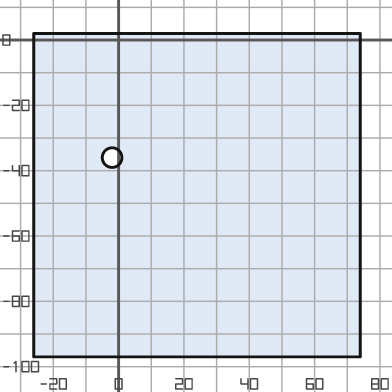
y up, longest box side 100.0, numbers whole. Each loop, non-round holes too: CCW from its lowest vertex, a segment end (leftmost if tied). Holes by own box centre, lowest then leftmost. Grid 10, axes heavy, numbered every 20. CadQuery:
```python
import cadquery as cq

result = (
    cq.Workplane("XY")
    .moveTo(-26.0, -97.0)
    .lineTo(74.0, -97.0)
    .lineTo(74.0, 2.0)
    .lineTo(-26.0, 2.0)
    .close()
    .moveTo(-2.0, -36.0)
    .circle(3.0)
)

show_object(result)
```